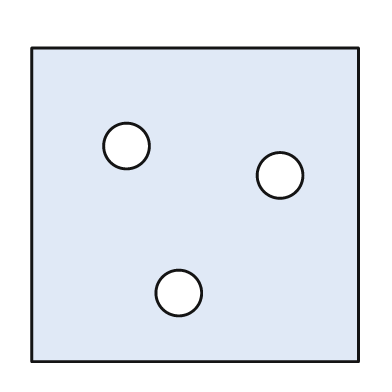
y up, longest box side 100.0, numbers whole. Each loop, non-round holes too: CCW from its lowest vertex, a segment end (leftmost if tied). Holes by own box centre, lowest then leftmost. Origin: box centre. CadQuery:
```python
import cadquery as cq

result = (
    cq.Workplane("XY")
    .moveTo(-50.0, -48.0)
    .lineTo(50.0, -48.0)
    .lineTo(50.0, 48.0)
    .lineTo(-50.0, 48.0)
    .close()
    .moveTo(-5.0, -27.0)
    .circle(7.0)
    .moveTo(26.0, 9.0)
    .circle(7.0)
    .moveTo(-21.0, 18.0)
    .circle(7.0)
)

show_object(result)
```